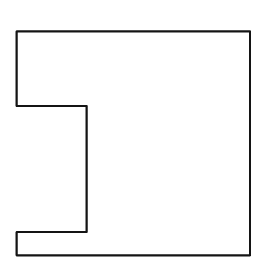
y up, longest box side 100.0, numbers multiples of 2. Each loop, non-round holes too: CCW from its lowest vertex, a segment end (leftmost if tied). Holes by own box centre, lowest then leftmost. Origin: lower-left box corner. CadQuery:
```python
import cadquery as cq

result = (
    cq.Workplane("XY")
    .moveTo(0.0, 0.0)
    .lineTo(100.0, 0.0)
    .lineTo(100.0, 96.0)
    .lineTo(0.0, 96.0)
    .lineTo(0.0, 64.0)
    .lineTo(30.0, 64.0)
    .lineTo(30.0, 10.0)
    .lineTo(0.0, 10.0)
    .close()
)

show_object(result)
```